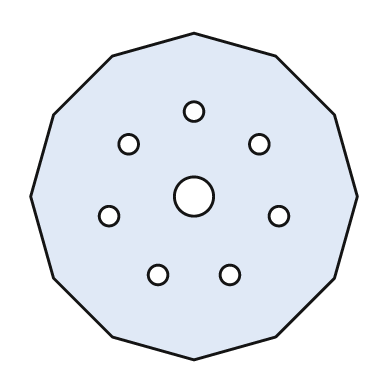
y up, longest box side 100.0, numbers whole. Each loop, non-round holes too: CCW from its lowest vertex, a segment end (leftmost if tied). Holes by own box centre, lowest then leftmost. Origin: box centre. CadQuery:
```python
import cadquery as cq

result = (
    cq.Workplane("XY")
    .moveTo(0.0, -50.0)
    .lineTo(25.0, -43.0)
    .lineTo(43.0, -25.0)
    .lineTo(50.0, 0.0)
    .lineTo(43.0, 25.0)
    .lineTo(25.0, 43.0)
    .lineTo(0.0, 50.0)
    .lineTo(-25.0, 43.0)
    .lineTo(-43.0, 25.0)
    .lineTo(-50.0, 0.0)
    .lineTo(-43.0, -25.0)
    .lineTo(-25.0, -43.0)
    .close()
    .moveTo(-11.0, -24.0)
    .circle(3.0)
    .moveTo(11.0, -24.0)
    .circle(3.0)
    .moveTo(-26.0, -6.0)
    .circle(3.0)
    .moveTo(26.0, -6.0)
    .circle(3.0)
    .moveTo(0.0, 0.0)
    .circle(6.0)
    .moveTo(-20.0, 16.0)
    .circle(3.0)
    .moveTo(20.0, 16.0)
    .circle(3.0)
    .moveTo(0.0, 26.0)
    .circle(3.0)
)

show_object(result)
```